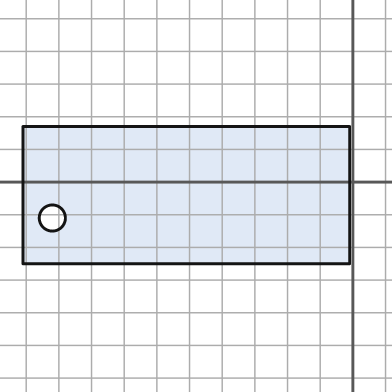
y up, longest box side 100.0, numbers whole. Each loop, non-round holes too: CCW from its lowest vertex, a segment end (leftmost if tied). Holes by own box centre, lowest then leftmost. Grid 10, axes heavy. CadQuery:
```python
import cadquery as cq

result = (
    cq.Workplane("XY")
    .moveTo(-101.0, -25.0)
    .lineTo(-1.0, -25.0)
    .lineTo(-1.0, 17.0)
    .lineTo(-101.0, 17.0)
    .close()
    .moveTo(-92.0, -11.0)
    .circle(4.0)
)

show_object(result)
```